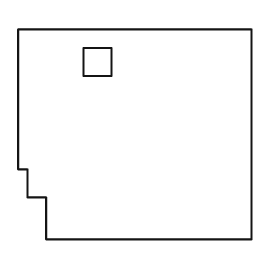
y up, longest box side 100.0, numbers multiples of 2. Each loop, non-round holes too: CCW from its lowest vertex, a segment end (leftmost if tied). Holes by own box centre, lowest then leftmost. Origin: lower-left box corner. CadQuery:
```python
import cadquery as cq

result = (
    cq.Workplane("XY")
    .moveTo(12.0, 0.0)
    .lineTo(100.0, 0.0)
    .lineTo(100.0, 90.0)
    .lineTo(0.0, 90.0)
    .lineTo(0.0, 30.0)
    .lineTo(4.0, 30.0)
    .lineTo(4.0, 18.0)
    .lineTo(12.0, 18.0)
    .close()
    .moveTo(28.0, 70.0)
    .lineTo(40.0, 70.0)
    .lineTo(40.0, 82.0)
    .lineTo(28.0, 82.0)
    .close()
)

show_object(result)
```